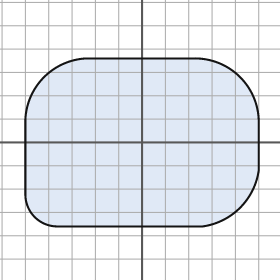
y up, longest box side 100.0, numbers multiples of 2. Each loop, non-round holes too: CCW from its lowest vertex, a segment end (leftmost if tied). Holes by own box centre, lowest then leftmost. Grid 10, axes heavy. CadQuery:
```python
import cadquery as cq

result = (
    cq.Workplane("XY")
    .moveTo(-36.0, -36.0)
    .lineTo(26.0, -36.0)
    .threePointArc((42.0, -28.0), (50.0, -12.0))
    .lineTo(50.0, 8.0)
    .threePointArc((42.0, 28.0), (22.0, 36.0))
    .lineTo(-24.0, 36.0)
    .threePointArc((-42.0, 28.0), (-50.0, 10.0))
    .lineTo(-50.0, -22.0)
    .threePointArc((-46.0, -32.0), (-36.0, -36.0))
    .close()
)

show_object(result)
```